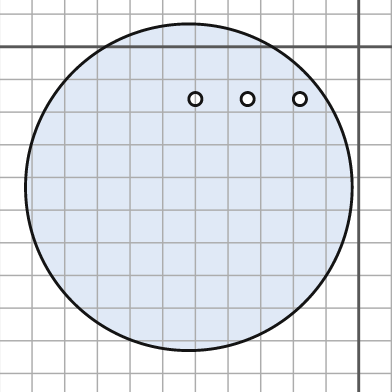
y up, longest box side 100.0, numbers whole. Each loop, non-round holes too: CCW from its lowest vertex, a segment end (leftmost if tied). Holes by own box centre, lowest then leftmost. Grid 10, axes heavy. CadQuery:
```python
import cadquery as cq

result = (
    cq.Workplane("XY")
    .moveTo(-52.0, -43.0)
    .circle(50.0)
    .moveTo(-50.0, -16.0)
    .circle(2.0)
    .moveTo(-34.0, -16.0)
    .circle(2.0)
    .moveTo(-18.0, -16.0)
    .circle(2.0)
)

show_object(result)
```